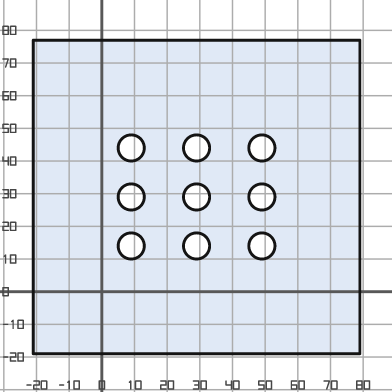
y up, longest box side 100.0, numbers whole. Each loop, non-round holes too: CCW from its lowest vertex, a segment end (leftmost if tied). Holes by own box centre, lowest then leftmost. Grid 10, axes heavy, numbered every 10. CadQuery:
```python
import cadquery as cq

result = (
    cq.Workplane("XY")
    .moveTo(-21.0, -19.0)
    .lineTo(79.0, -19.0)
    .lineTo(79.0, 77.0)
    .lineTo(-21.0, 77.0)
    .close()
    .moveTo(9.0, 14.0)
    .circle(4.0)
    .moveTo(29.0, 14.0)
    .circle(4.0)
    .moveTo(49.0, 14.0)
    .circle(4.0)
    .moveTo(9.0, 29.0)
    .circle(4.0)
    .moveTo(29.0, 29.0)
    .circle(4.0)
    .moveTo(49.0, 29.0)
    .circle(4.0)
    .moveTo(9.0, 44.0)
    .circle(4.0)
    .moveTo(29.0, 44.0)
    .circle(4.0)
    .moveTo(49.0, 44.0)
    .circle(4.0)
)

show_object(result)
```